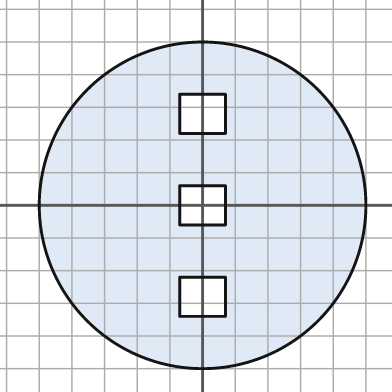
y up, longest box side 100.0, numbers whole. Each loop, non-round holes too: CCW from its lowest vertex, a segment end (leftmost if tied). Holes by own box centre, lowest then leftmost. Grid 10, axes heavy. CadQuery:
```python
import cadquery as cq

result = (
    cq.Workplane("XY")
    .moveTo(0.0, 0.0)
    .circle(50.0)
    .moveTo(-7.0, -34.0)
    .lineTo(7.0, -34.0)
    .lineTo(7.0, -22.0)
    .lineTo(-7.0, -22.0)
    .close()
    .moveTo(-7.0, -6.0)
    .lineTo(7.0, -6.0)
    .lineTo(7.0, 6.0)
    .lineTo(-7.0, 6.0)
    .close()
    .moveTo(-7.0, 22.0)
    .lineTo(7.0, 22.0)
    .lineTo(7.0, 34.0)
    .lineTo(-7.0, 34.0)
    .close()
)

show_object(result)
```